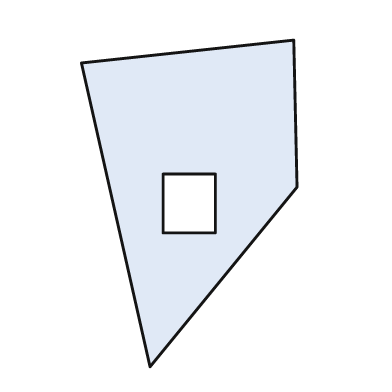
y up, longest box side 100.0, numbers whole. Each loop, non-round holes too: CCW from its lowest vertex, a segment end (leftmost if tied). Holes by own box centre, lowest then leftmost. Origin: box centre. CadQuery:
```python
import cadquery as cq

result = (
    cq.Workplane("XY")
    .moveTo(-12.0, -50.0)
    .lineTo(33.0, 5.0)
    .lineTo(32.0, 50.0)
    .lineTo(-33.0, 43.0)
    .close()
    .moveTo(-8.0, -9.0)
    .lineTo(8.0, -9.0)
    .lineTo(8.0, 9.0)
    .lineTo(-8.0, 9.0)
    .close()
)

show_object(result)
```